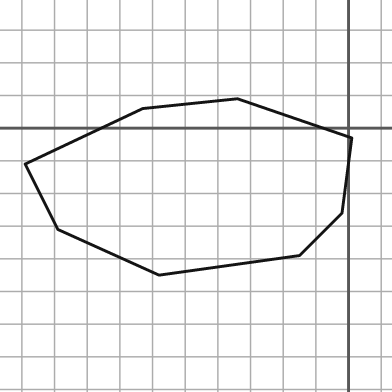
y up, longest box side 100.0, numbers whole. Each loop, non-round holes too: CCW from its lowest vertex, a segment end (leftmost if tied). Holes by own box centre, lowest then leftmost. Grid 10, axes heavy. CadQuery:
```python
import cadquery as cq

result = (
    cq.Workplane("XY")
    .moveTo(-58.0, -45.0)
    .lineTo(-15.0, -39.0)
    .lineTo(-2.0, -26.0)
    .lineTo(1.0, -3.0)
    .lineTo(-34.0, 9.0)
    .lineTo(-63.0, 6.0)
    .lineTo(-99.0, -11.0)
    .lineTo(-89.0, -31.0)
    .close()
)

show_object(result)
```